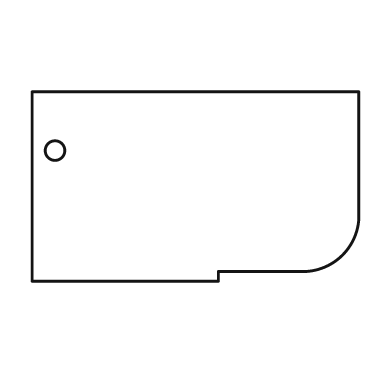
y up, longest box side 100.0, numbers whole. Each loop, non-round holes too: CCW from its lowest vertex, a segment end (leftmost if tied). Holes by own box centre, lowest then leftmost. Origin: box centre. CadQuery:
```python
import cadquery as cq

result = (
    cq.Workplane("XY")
    .moveTo(-50.0, -29.0)
    .lineTo(7.0, -29.0)
    .lineTo(7.0, -26.0)
    .lineTo(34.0, -26.0)
    .threePointArc((45.0, -21.0), (50.0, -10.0))
    .lineTo(50.0, 29.0)
    .lineTo(-50.0, 29.0)
    .close()
    .moveTo(-43.0, 11.0)
    .circle(3.0)
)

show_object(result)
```